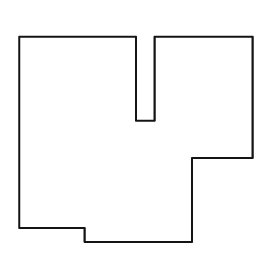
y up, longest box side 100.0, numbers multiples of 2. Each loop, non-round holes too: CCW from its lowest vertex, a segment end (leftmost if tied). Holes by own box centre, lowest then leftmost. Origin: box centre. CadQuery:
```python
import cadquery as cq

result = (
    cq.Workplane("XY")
    .moveTo(-22.0, -44.0)
    .lineTo(24.0, -44.0)
    .lineTo(24.0, -8.0)
    .lineTo(50.0, -8.0)
    .lineTo(50.0, 44.0)
    .lineTo(8.0, 44.0)
    .lineTo(8.0, 8.0)
    .lineTo(0.0, 8.0)
    .lineTo(0.0, 44.0)
    .lineTo(-50.0, 44.0)
    .lineTo(-50.0, -38.0)
    .lineTo(-22.0, -38.0)
    .close()
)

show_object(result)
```